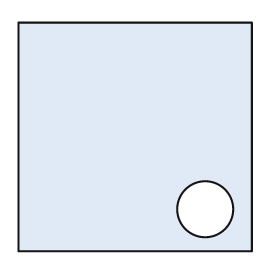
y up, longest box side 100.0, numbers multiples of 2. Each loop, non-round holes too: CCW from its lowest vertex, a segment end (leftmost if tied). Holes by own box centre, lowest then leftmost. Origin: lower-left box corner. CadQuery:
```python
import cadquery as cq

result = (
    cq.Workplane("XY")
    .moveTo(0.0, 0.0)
    .lineTo(100.0, 0.0)
    .lineTo(100.0, 98.0)
    .lineTo(0.0, 98.0)
    .close()
    .moveTo(80.0, 18.0)
    .circle(12.0)
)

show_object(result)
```